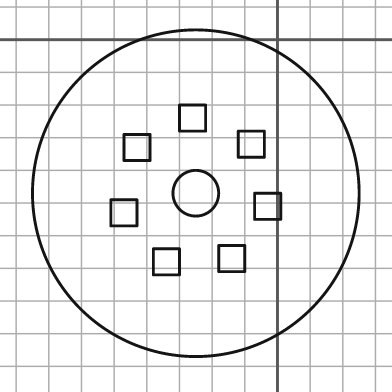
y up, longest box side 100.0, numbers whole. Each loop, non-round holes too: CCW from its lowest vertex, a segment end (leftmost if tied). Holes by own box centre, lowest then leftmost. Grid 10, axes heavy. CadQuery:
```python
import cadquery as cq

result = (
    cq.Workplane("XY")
    .moveTo(-25.0, -47.0)
    .circle(50.0)
    .moveTo(-38.0, -72.0)
    .lineTo(-30.0, -72.0)
    .lineTo(-30.0, -64.0)
    .lineTo(-38.0, -64.0)
    .close()
    .moveTo(-18.0, -71.0)
    .lineTo(-10.0, -71.0)
    .lineTo(-10.0, -63.0)
    .lineTo(-18.0, -63.0)
    .close()
    .moveTo(-51.0, -57.0)
    .lineTo(-43.0, -57.0)
    .lineTo(-43.0, -49.0)
    .lineTo(-51.0, -49.0)
    .close()
    .moveTo(-7.0, -55.0)
    .lineTo(1.0, -55.0)
    .lineTo(1.0, -47.0)
    .lineTo(-7.0, -47.0)
    .close()
    .moveTo(-25.0, -47.0)
    .circle(7.0)
    .moveTo(-47.0, -37.0)
    .lineTo(-39.0, -37.0)
    .lineTo(-39.0, -29.0)
    .lineTo(-47.0, -29.0)
    .close()
    .moveTo(-12.0, -36.0)
    .lineTo(-4.0, -36.0)
    .lineTo(-4.0, -28.0)
    .lineTo(-12.0, -28.0)
    .close()
    .moveTo(-30.0, -28.0)
    .lineTo(-22.0, -28.0)
    .lineTo(-22.0, -20.0)
    .lineTo(-30.0, -20.0)
    .close()
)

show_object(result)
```